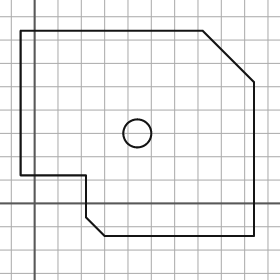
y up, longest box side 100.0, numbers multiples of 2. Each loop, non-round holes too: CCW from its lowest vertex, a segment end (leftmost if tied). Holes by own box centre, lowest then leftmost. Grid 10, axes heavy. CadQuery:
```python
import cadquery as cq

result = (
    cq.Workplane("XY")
    .moveTo(30.0, -14.0)
    .lineTo(94.0, -14.0)
    .lineTo(94.0, 52.0)
    .lineTo(72.0, 74.0)
    .lineTo(-6.0, 74.0)
    .lineTo(-6.0, 12.0)
    .lineTo(22.0, 12.0)
    .lineTo(22.0, -6.0)
    .close()
    .moveTo(44.0, 30.0)
    .circle(6.0)
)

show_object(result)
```